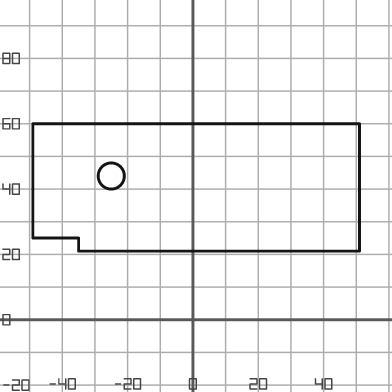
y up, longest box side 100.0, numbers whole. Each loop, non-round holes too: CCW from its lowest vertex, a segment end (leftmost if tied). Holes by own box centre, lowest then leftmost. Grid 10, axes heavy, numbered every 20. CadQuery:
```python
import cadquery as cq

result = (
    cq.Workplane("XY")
    .moveTo(-35.0, 21.0)
    .lineTo(51.0, 21.0)
    .lineTo(51.0, 60.0)
    .lineTo(-49.0, 60.0)
    .lineTo(-49.0, 25.0)
    .lineTo(-35.0, 25.0)
    .close()
    .moveTo(-25.0, 44.0)
    .circle(4.0)
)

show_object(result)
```